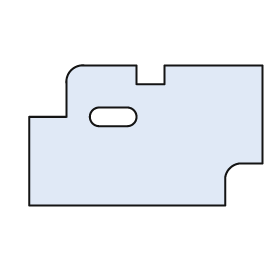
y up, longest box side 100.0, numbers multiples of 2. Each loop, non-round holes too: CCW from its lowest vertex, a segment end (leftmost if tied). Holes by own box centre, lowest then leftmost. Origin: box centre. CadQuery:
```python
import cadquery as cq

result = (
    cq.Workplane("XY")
    .moveTo(-50.0, -30.0)
    .lineTo(34.0, -30.0)
    .lineTo(34.0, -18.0)
    .threePointArc((36.0, -14.0), (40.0, -12.0))
    .lineTo(50.0, -12.0)
    .lineTo(50.0, 30.0)
    .lineTo(8.0, 30.0)
    .lineTo(8.0, 22.0)
    .lineTo(-4.0, 22.0)
    .lineTo(-4.0, 30.0)
    .lineTo(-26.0, 30.0)
    .threePointArc((-32.0, 28.0), (-34.0, 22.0))
    .lineTo(-34.0, 8.0)
    .lineTo(-50.0, 8.0)
    .close()
    .moveTo(-20.0, 4.0)
    .lineTo(-8.0, 4.0)
    .threePointArc((-4.0, 8.0), (-8.0, 12.0))
    .lineTo(-20.0, 12.0)
    .threePointArc((-24.0, 8.0), (-20.0, 4.0))
    .close()
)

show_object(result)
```